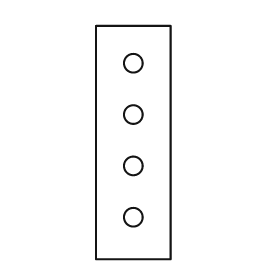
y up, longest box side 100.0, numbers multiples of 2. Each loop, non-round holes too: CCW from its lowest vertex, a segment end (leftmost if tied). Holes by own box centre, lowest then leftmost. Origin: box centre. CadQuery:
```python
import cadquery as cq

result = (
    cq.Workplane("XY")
    .moveTo(-16.0, -50.0)
    .lineTo(16.0, -50.0)
    .lineTo(16.0, 50.0)
    .lineTo(-16.0, 50.0)
    .close()
    .moveTo(0.0, -32.0)
    .circle(4.0)
    .moveTo(0.0, -10.0)
    .circle(4.0)
    .moveTo(0.0, 12.0)
    .circle(4.0)
    .moveTo(0.0, 34.0)
    .circle(4.0)
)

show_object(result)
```